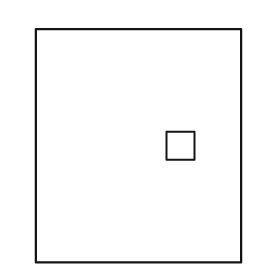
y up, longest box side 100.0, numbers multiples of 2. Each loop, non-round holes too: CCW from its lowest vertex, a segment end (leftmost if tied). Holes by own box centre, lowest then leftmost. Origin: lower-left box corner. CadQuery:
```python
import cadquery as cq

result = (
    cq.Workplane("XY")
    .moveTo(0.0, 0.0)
    .lineTo(88.0, 0.0)
    .lineTo(88.0, 100.0)
    .lineTo(0.0, 100.0)
    .close()
    .moveTo(56.0, 44.0)
    .lineTo(68.0, 44.0)
    .lineTo(68.0, 56.0)
    .lineTo(56.0, 56.0)
    .close()
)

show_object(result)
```